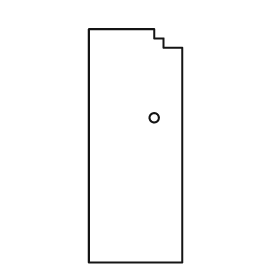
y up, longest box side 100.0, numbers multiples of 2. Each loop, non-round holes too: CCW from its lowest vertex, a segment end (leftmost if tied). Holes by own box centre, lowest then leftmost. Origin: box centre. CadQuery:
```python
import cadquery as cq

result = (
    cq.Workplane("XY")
    .moveTo(-20.0, -50.0)
    .lineTo(20.0, -50.0)
    .lineTo(20.0, 42.0)
    .lineTo(12.0, 42.0)
    .lineTo(12.0, 46.0)
    .lineTo(8.0, 46.0)
    .lineTo(8.0, 50.0)
    .lineTo(-20.0, 50.0)
    .close()
    .moveTo(8.0, 12.0)
    .circle(2.0)
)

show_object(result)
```